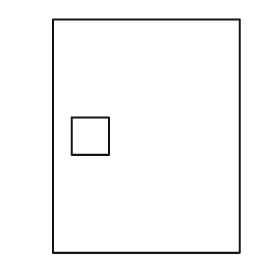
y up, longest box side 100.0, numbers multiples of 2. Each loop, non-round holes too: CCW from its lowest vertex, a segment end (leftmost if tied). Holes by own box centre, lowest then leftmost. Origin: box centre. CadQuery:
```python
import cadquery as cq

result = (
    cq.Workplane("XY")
    .moveTo(-40.0, -50.0)
    .lineTo(40.0, -50.0)
    .lineTo(40.0, 50.0)
    .lineTo(-40.0, 50.0)
    .close()
    .moveTo(-32.0, -8.0)
    .lineTo(-16.0, -8.0)
    .lineTo(-16.0, 8.0)
    .lineTo(-32.0, 8.0)
    .close()
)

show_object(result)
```